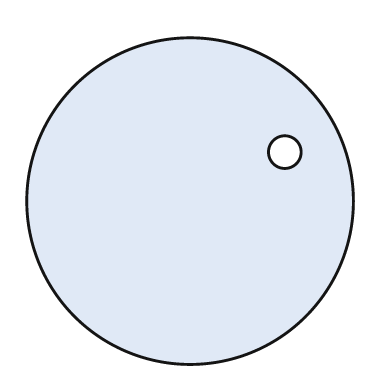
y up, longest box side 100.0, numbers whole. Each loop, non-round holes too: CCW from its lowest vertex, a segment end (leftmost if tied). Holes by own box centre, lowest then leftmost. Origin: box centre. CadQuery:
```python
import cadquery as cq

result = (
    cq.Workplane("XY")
    .moveTo(0.0, 0.0)
    .circle(50.0)
    .moveTo(29.0, 15.0)
    .circle(5.0)
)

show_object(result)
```